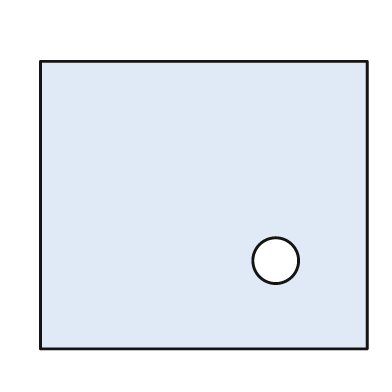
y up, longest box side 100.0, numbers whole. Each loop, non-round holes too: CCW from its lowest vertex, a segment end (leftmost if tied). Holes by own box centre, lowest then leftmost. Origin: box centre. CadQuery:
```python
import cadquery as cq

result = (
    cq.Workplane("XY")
    .moveTo(-50.0, -44.0)
    .lineTo(50.0, -44.0)
    .lineTo(50.0, 44.0)
    .lineTo(-50.0, 44.0)
    .close()
    .moveTo(22.0, -17.0)
    .circle(7.0)
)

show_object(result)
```